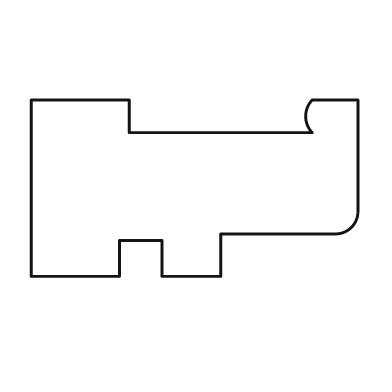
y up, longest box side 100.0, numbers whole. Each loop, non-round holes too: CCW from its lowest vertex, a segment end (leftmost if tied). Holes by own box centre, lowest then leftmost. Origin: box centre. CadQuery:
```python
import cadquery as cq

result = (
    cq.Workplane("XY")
    .moveTo(-50.0, -27.0)
    .lineTo(-23.0, -27.0)
    .lineTo(-23.0, -16.0)
    .lineTo(-10.0, -16.0)
    .lineTo(-10.0, -27.0)
    .lineTo(8.0, -27.0)
    .lineTo(8.0, -14.0)
    .lineTo(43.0, -14.0)
    .threePointArc((48.0, -12.0), (50.0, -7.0))
    .lineTo(50.0, 27.0)
    .lineTo(36.0, 27.0)
    .threePointArc((34.0, 22.0), (36.0, 17.0))
    .lineTo(-20.0, 17.0)
    .lineTo(-20.0, 27.0)
    .lineTo(-50.0, 27.0)
    .close()
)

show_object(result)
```